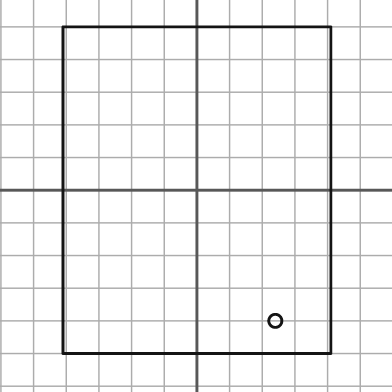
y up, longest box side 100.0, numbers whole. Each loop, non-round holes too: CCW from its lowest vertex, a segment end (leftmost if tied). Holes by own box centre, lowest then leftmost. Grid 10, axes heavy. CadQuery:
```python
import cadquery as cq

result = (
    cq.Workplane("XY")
    .moveTo(-41.0, -50.0)
    .lineTo(41.0, -50.0)
    .lineTo(41.0, 50.0)
    .lineTo(-41.0, 50.0)
    .close()
    .moveTo(24.0, -40.0)
    .circle(2.0)
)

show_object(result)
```